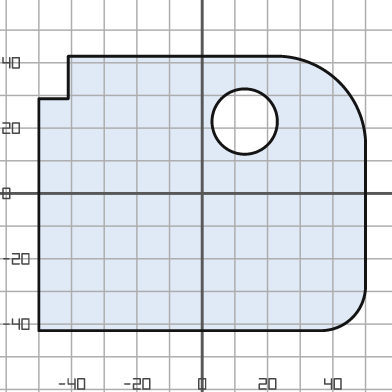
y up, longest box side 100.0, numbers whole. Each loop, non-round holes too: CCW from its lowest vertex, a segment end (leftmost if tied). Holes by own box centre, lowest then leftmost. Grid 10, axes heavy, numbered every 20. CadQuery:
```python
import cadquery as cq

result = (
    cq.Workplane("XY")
    .moveTo(-50.0, -42.0)
    .lineTo(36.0, -42.0)
    .threePointArc((46.0, -38.0), (50.0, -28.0))
    .lineTo(50.0, 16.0)
    .threePointArc((42.0, 34.0), (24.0, 42.0))
    .lineTo(-41.0, 42.0)
    .lineTo(-41.0, 29.0)
    .lineTo(-50.0, 29.0)
    .close()
    .moveTo(13.0, 22.0)
    .circle(10.0)
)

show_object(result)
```